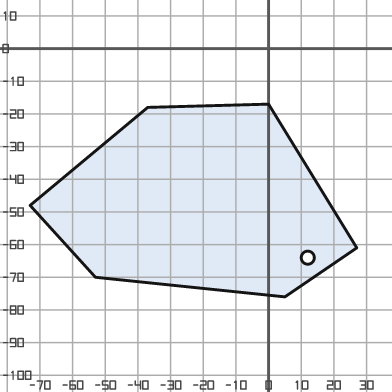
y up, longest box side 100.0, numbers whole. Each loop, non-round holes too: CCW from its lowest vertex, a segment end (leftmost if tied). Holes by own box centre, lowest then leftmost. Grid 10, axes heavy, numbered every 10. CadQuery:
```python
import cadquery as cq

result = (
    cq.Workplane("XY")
    .moveTo(5.0, -76.0)
    .lineTo(27.0, -61.0)
    .lineTo(0.0, -17.0)
    .lineTo(-37.0, -18.0)
    .lineTo(-73.0, -48.0)
    .lineTo(-53.0, -70.0)
    .close()
    .moveTo(12.0, -64.0)
    .circle(2.0)
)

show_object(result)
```